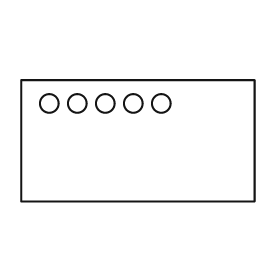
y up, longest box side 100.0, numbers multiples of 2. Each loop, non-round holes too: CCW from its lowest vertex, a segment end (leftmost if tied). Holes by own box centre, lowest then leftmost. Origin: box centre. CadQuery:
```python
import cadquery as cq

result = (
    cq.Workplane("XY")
    .moveTo(-50.0, -26.0)
    .lineTo(50.0, -26.0)
    .lineTo(50.0, 26.0)
    .lineTo(-50.0, 26.0)
    .close()
    .moveTo(-38.0, 16.0)
    .circle(4.0)
    .moveTo(-26.0, 16.0)
    .circle(4.0)
    .moveTo(-14.0, 16.0)
    .circle(4.0)
    .moveTo(-2.0, 16.0)
    .circle(4.0)
    .moveTo(10.0, 16.0)
    .circle(4.0)
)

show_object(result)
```